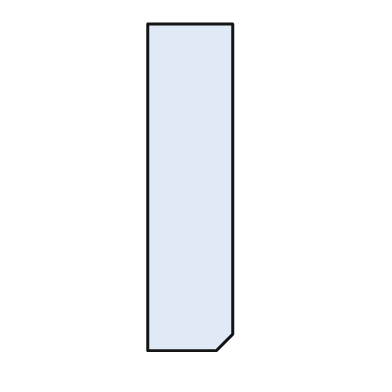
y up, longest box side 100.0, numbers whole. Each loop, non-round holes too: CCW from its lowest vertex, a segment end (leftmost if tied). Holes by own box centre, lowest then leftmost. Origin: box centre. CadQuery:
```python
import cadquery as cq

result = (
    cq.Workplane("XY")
    .moveTo(-13.0, -50.0)
    .lineTo(8.0, -50.0)
    .lineTo(13.0, -45.0)
    .lineTo(13.0, 50.0)
    .lineTo(-13.0, 50.0)
    .close()
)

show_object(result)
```